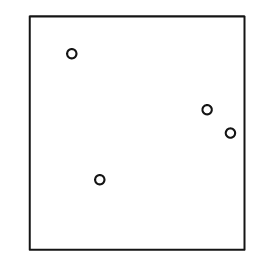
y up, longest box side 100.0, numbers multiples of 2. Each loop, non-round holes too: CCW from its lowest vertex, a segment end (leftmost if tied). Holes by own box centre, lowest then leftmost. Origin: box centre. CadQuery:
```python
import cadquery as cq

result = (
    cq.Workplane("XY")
    .moveTo(-46.0, -50.0)
    .lineTo(46.0, -50.0)
    .lineTo(46.0, 50.0)
    .lineTo(-46.0, 50.0)
    .close()
    .moveTo(-16.0, -20.0)
    .circle(2.0)
    .moveTo(40.0, 0.0)
    .circle(2.0)
    .moveTo(30.0, 10.0)
    .circle(2.0)
    .moveTo(-28.0, 34.0)
    .circle(2.0)
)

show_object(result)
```